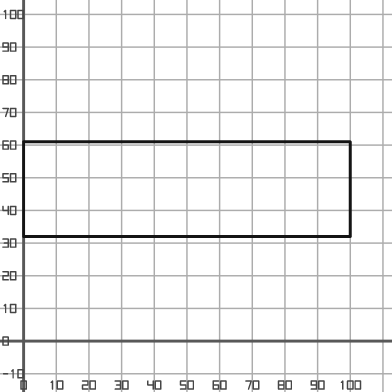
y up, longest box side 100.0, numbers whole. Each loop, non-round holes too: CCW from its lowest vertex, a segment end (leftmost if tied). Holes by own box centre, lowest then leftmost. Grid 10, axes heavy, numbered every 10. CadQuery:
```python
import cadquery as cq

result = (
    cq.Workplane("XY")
    .moveTo(0.0, 32.0)
    .lineTo(100.0, 32.0)
    .lineTo(100.0, 61.0)
    .lineTo(0.0, 61.0)
    .close()
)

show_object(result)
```